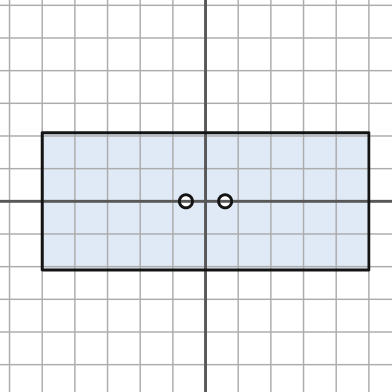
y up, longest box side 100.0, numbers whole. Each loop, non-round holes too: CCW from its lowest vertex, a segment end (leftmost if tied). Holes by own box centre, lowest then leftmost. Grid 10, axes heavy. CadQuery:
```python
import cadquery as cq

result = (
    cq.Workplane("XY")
    .moveTo(-50.0, -21.0)
    .lineTo(50.0, -21.0)
    .lineTo(50.0, 21.0)
    .lineTo(-50.0, 21.0)
    .close()
    .moveTo(-6.0, 0.0)
    .circle(2.0)
    .moveTo(6.0, 0.0)
    .circle(2.0)
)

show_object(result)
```